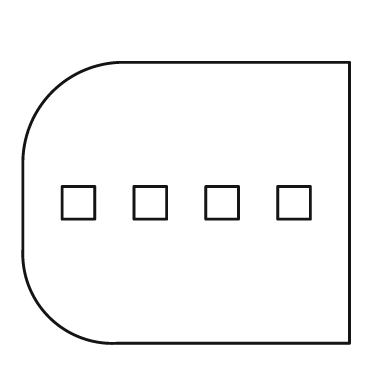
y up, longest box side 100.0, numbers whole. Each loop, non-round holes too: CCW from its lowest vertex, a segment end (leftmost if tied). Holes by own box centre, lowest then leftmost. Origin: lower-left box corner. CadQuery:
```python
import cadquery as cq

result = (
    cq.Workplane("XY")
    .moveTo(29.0, 0.0)
    .lineTo(100.0, 0.0)
    .lineTo(100.0, 86.0)
    .lineTo(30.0, 86.0)
    .threePointArc((9.0, 77.0), (0.0, 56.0))
    .lineTo(0.0, 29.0)
    .threePointArc((8.0, 8.0), (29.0, 0.0))
    .close()
    .moveTo(12.0, 38.0)
    .lineTo(22.0, 38.0)
    .lineTo(22.0, 48.0)
    .lineTo(12.0, 48.0)
    .close()
    .moveTo(34.0, 38.0)
    .lineTo(44.0, 38.0)
    .lineTo(44.0, 48.0)
    .lineTo(34.0, 48.0)
    .close()
    .moveTo(56.0, 38.0)
    .lineTo(66.0, 38.0)
    .lineTo(66.0, 48.0)
    .lineTo(56.0, 48.0)
    .close()
    .moveTo(78.0, 38.0)
    .lineTo(88.0, 38.0)
    .lineTo(88.0, 48.0)
    .lineTo(78.0, 48.0)
    .close()
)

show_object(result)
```